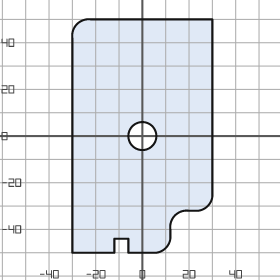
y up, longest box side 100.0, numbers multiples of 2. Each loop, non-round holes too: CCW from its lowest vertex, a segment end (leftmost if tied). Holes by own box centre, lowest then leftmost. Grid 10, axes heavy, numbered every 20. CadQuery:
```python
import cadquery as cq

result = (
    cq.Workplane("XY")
    .moveTo(-30.0, -50.0)
    .lineTo(-12.0, -50.0)
    .lineTo(-12.0, -44.0)
    .lineTo(-6.0, -44.0)
    .lineTo(-6.0, -50.0)
    .lineTo(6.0, -50.0)
    .threePointArc((10.0, -48.0), (12.0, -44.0))
    .lineTo(12.0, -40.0)
    .threePointArc((14.0, -34.0), (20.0, -32.0))
    .lineTo(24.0, -32.0)
    .threePointArc((28.0, -30.0), (30.0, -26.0))
    .lineTo(30.0, 50.0)
    .lineTo(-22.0, 50.0)
    .threePointArc((-28.0, 48.0), (-30.0, 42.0))
    .close()
    .moveTo(0.0, 0.0)
    .circle(6.0)
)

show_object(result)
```